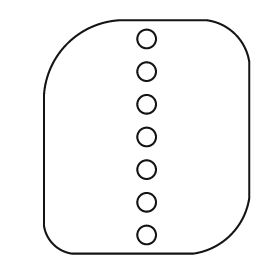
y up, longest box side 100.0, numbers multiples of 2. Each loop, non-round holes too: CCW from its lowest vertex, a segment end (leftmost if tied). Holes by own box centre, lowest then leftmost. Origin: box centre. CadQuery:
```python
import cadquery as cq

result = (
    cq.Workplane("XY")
    .moveTo(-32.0, -50.0)
    .lineTo(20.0, -50.0)
    .threePointArc((36.0, -42.0), (44.0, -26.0))
    .lineTo(44.0, 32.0)
    .threePointArc((38.0, 44.0), (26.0, 50.0))
    .lineTo(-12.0, 50.0)
    .threePointArc((-34.0, 40.0), (-44.0, 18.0))
    .lineTo(-44.0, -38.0)
    .threePointArc((-40.0, -46.0), (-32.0, -50.0))
    .close()
    .moveTo(0.0, -42.0)
    .circle(4.0)
    .moveTo(0.0, -28.0)
    .circle(4.0)
    .moveTo(0.0, -14.0)
    .circle(4.0)
    .moveTo(0.0, 0.0)
    .circle(4.0)
    .moveTo(0.0, 14.0)
    .circle(4.0)
    .moveTo(0.0, 28.0)
    .circle(4.0)
    .moveTo(0.0, 42.0)
    .circle(4.0)
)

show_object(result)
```